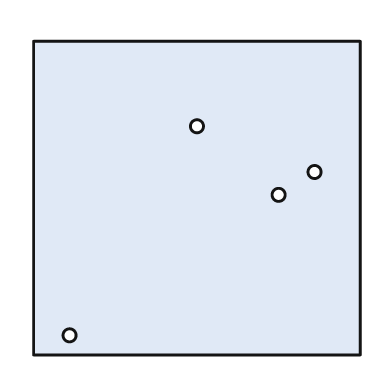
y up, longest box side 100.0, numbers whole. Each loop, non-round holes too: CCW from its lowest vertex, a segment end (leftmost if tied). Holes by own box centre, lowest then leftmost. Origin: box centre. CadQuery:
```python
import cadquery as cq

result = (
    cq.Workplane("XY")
    .moveTo(-50.0, -48.0)
    .lineTo(50.0, -48.0)
    .lineTo(50.0, 48.0)
    .lineTo(-50.0, 48.0)
    .close()
    .moveTo(-39.0, -42.0)
    .circle(2.0)
    .moveTo(25.0, 1.0)
    .circle(2.0)
    .moveTo(36.0, 8.0)
    .circle(2.0)
    .moveTo(0.0, 22.0)
    .circle(2.0)
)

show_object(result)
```